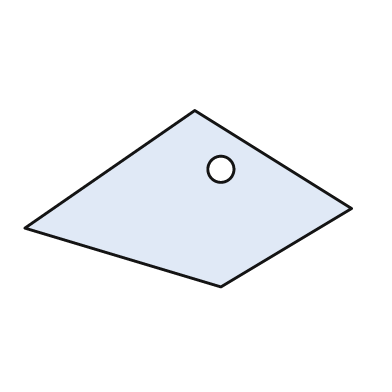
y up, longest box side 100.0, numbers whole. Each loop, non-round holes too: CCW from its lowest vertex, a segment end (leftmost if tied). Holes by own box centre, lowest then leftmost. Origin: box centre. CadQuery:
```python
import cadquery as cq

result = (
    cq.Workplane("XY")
    .moveTo(10.0, -27.0)
    .lineTo(50.0, -3.0)
    .lineTo(2.0, 27.0)
    .lineTo(-50.0, -9.0)
    .close()
    .moveTo(10.0, 9.0)
    .circle(4.0)
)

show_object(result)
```